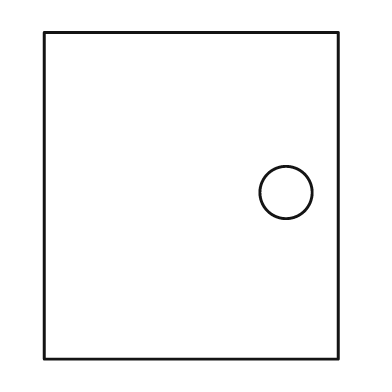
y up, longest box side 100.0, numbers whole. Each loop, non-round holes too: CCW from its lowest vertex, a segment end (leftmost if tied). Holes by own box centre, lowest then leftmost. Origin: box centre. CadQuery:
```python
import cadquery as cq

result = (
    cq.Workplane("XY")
    .moveTo(-45.0, -50.0)
    .lineTo(45.0, -50.0)
    .lineTo(45.0, 50.0)
    .lineTo(-45.0, 50.0)
    .close()
    .moveTo(29.0, 1.0)
    .circle(8.0)
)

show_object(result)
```